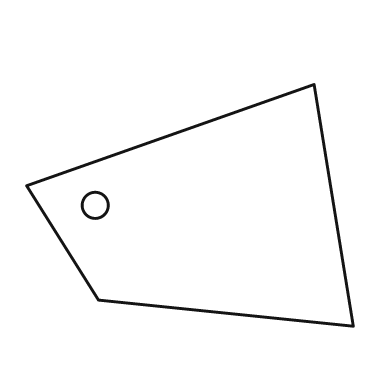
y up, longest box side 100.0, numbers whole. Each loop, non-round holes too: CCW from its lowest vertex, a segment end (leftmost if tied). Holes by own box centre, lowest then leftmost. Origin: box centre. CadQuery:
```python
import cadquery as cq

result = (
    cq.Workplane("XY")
    .moveTo(50.0, -37.0)
    .lineTo(38.0, 37.0)
    .lineTo(-50.0, 6.0)
    .lineTo(-28.0, -29.0)
    .close()
    .moveTo(-29.0, 0.0)
    .circle(4.0)
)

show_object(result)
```